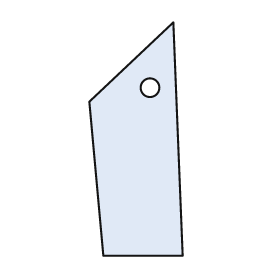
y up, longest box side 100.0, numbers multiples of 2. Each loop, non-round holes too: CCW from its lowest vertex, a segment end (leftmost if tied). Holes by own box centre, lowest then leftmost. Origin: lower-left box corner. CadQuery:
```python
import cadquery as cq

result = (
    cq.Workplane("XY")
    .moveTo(6.0, 0.0)
    .lineTo(40.0, 0.0)
    .lineTo(36.0, 100.0)
    .lineTo(0.0, 66.0)
    .close()
    .moveTo(26.0, 72.0)
    .circle(4.0)
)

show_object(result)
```